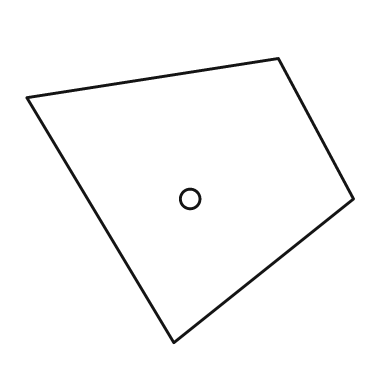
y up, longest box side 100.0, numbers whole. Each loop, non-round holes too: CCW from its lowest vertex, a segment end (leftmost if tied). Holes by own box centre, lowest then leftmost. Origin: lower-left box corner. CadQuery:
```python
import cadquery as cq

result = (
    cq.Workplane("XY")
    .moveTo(45.0, 0.0)
    .lineTo(100.0, 44.0)
    .lineTo(77.0, 87.0)
    .lineTo(0.0, 75.0)
    .close()
    .moveTo(50.0, 44.0)
    .circle(3.0)
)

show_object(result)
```